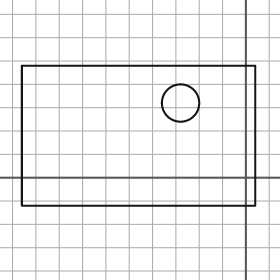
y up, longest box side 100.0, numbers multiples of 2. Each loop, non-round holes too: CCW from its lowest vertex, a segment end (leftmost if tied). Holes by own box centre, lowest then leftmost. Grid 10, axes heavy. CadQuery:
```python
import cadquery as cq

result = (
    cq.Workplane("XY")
    .moveTo(-96.0, -12.0)
    .lineTo(4.0, -12.0)
    .lineTo(4.0, 48.0)
    .lineTo(-96.0, 48.0)
    .close()
    .moveTo(-28.0, 32.0)
    .circle(8.0)
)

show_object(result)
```